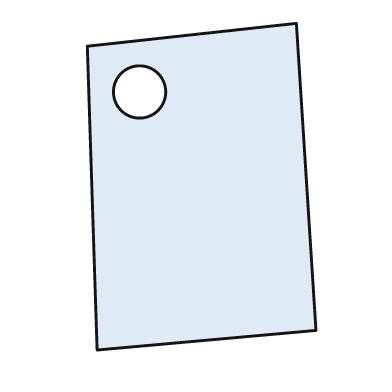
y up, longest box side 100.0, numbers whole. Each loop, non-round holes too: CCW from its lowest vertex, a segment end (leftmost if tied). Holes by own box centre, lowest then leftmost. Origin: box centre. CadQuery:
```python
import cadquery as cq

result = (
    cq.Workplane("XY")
    .moveTo(-32.0, -50.0)
    .lineTo(35.0, -44.0)
    .lineTo(29.0, 50.0)
    .lineTo(-35.0, 43.0)
    .close()
    .moveTo(-19.0, 29.0)
    .circle(8.0)
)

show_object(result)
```